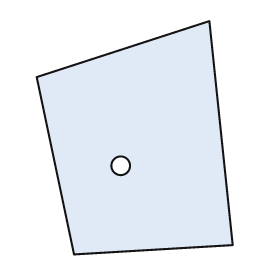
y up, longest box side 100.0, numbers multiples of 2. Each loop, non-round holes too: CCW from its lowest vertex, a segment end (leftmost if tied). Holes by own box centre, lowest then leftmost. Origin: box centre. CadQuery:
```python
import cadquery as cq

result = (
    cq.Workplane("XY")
    .moveTo(-26.0, -50.0)
    .lineTo(42.0, -46.0)
    .lineTo(32.0, 50.0)
    .lineTo(-42.0, 26.0)
    .close()
    .moveTo(-6.0, -12.0)
    .circle(4.0)
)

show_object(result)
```